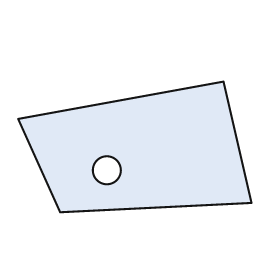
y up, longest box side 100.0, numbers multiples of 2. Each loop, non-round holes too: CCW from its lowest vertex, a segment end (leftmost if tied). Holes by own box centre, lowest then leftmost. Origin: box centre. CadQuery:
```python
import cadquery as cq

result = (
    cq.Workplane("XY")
    .moveTo(-32.0, -28.0)
    .lineTo(50.0, -24.0)
    .lineTo(38.0, 28.0)
    .lineTo(-50.0, 12.0)
    .close()
    .moveTo(-12.0, -10.0)
    .circle(6.0)
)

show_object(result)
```